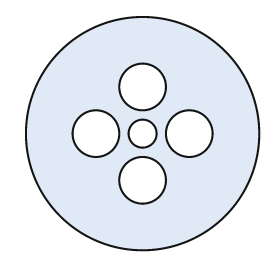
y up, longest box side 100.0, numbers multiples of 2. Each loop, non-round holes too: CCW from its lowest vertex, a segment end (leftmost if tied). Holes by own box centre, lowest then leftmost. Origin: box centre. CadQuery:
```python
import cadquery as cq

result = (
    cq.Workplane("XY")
    .moveTo(0.0, 0.0)
    .circle(50.0)
    .moveTo(0.0, -20.0)
    .circle(10.0)
    .moveTo(-20.0, 0.0)
    .circle(10.0)
    .moveTo(0.0, 0.0)
    .circle(6.0)
    .moveTo(20.0, 0.0)
    .circle(10.0)
    .moveTo(0.0, 20.0)
    .circle(10.0)
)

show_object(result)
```